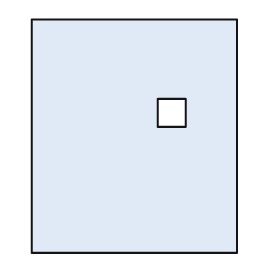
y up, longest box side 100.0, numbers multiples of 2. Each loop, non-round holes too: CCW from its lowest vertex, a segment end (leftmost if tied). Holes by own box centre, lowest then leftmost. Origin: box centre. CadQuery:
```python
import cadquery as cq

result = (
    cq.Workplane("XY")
    .moveTo(-44.0, -50.0)
    .lineTo(44.0, -50.0)
    .lineTo(44.0, 50.0)
    .lineTo(-44.0, 50.0)
    .close()
    .moveTo(10.0, 4.0)
    .lineTo(22.0, 4.0)
    .lineTo(22.0, 16.0)
    .lineTo(10.0, 16.0)
    .close()
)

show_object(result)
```